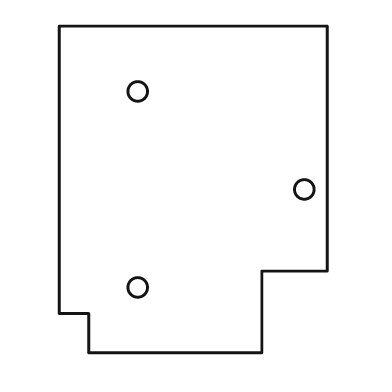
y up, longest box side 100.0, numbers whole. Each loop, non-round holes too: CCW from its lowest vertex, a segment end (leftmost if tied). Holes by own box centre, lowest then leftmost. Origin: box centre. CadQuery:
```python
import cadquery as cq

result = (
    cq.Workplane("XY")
    .moveTo(-32.0, -50.0)
    .lineTo(21.0, -50.0)
    .lineTo(21.0, -25.0)
    .lineTo(41.0, -25.0)
    .lineTo(41.0, 50.0)
    .lineTo(-41.0, 50.0)
    .lineTo(-41.0, -38.0)
    .lineTo(-32.0, -38.0)
    .close()
    .moveTo(-17.0, -30.0)
    .circle(3.0)
    .moveTo(34.0, 0.0)
    .circle(3.0)
    .moveTo(-17.0, 30.0)
    .circle(3.0)
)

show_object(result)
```